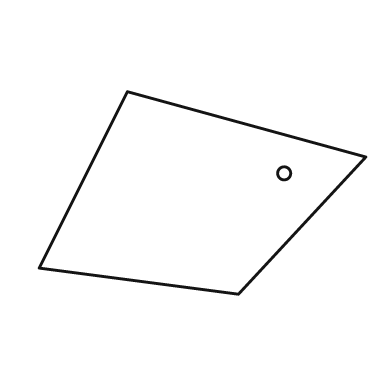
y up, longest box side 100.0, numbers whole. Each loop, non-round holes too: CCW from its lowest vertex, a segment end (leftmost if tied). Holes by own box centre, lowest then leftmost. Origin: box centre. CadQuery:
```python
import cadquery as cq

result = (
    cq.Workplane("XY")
    .moveTo(11.0, -31.0)
    .lineTo(50.0, 11.0)
    .lineTo(-23.0, 31.0)
    .lineTo(-50.0, -23.0)
    .close()
    .moveTo(25.0, 6.0)
    .circle(2.0)
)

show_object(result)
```